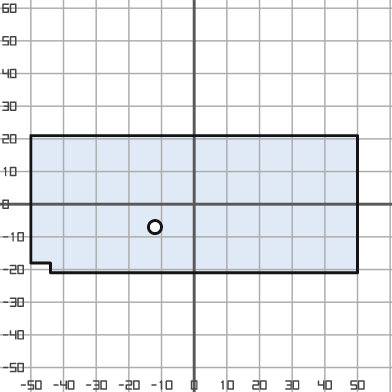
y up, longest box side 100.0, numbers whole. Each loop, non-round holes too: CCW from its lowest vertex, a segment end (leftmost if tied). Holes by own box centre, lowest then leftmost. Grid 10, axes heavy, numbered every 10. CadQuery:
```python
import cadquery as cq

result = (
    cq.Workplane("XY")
    .moveTo(-44.0, -21.0)
    .lineTo(50.0, -21.0)
    .lineTo(50.0, 21.0)
    .lineTo(-50.0, 21.0)
    .lineTo(-50.0, -18.0)
    .lineTo(-44.0, -18.0)
    .close()
    .moveTo(-12.0, -7.0)
    .circle(2.0)
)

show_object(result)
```